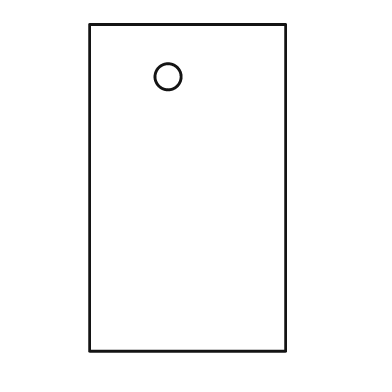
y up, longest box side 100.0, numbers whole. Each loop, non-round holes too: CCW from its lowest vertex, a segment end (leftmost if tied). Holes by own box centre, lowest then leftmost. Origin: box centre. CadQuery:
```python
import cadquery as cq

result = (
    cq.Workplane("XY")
    .moveTo(-30.0, -50.0)
    .lineTo(30.0, -50.0)
    .lineTo(30.0, 50.0)
    .lineTo(-30.0, 50.0)
    .close()
    .moveTo(-6.0, 34.0)
    .circle(4.0)
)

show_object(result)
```